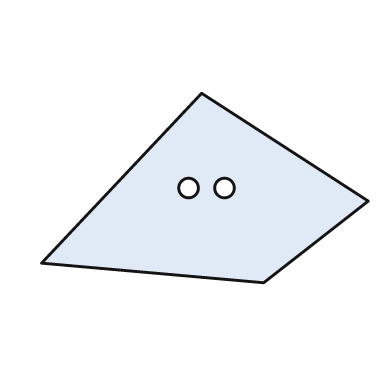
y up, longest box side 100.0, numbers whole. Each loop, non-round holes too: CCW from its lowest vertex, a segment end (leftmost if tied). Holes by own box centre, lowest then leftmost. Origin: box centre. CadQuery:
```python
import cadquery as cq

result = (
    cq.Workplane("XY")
    .moveTo(18.0, -29.0)
    .lineTo(50.0, -4.0)
    .lineTo(-1.0, 29.0)
    .lineTo(-50.0, -23.0)
    .close()
    .moveTo(-5.0, 0.0)
    .circle(3.0)
    .moveTo(6.0, 0.0)
    .circle(3.0)
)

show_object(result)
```